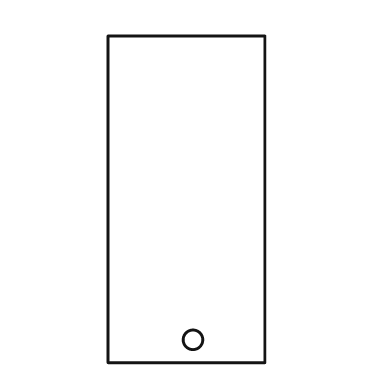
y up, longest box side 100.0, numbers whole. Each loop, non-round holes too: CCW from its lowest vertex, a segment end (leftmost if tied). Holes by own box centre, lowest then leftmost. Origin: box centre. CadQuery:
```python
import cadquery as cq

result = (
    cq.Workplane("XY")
    .moveTo(-24.0, -50.0)
    .lineTo(24.0, -50.0)
    .lineTo(24.0, 50.0)
    .lineTo(-24.0, 50.0)
    .close()
    .moveTo(2.0, -43.0)
    .circle(3.0)
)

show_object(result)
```